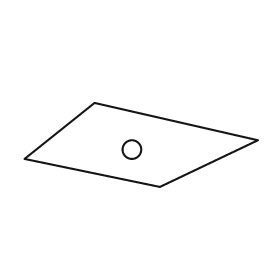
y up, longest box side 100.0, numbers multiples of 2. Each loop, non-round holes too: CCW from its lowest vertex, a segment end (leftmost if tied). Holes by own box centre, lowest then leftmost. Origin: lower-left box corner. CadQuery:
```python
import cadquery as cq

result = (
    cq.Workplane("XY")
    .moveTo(58.0, 0.0)
    .lineTo(100.0, 20.0)
    .lineTo(30.0, 36.0)
    .lineTo(0.0, 12.0)
    .close()
    .moveTo(46.0, 16.0)
    .circle(4.0)
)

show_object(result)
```